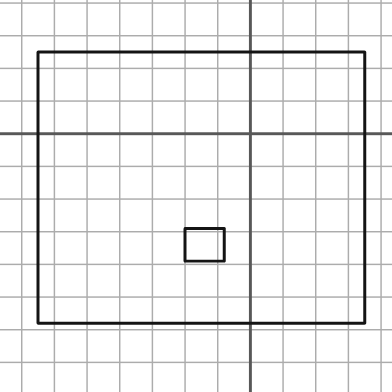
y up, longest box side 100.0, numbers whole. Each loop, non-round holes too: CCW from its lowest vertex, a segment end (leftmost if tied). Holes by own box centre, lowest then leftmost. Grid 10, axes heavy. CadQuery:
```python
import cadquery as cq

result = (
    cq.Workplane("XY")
    .moveTo(-65.0, -58.0)
    .lineTo(35.0, -58.0)
    .lineTo(35.0, 25.0)
    .lineTo(-65.0, 25.0)
    .close()
    .moveTo(-20.0, -39.0)
    .lineTo(-8.0, -39.0)
    .lineTo(-8.0, -29.0)
    .lineTo(-20.0, -29.0)
    .close()
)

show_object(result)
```